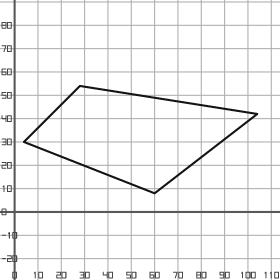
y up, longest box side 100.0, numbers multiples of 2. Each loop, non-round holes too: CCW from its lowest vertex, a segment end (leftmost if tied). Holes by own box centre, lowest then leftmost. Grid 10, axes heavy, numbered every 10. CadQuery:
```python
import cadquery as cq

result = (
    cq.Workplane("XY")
    .moveTo(60.0, 8.0)
    .lineTo(104.0, 42.0)
    .lineTo(28.0, 54.0)
    .lineTo(4.0, 30.0)
    .close()
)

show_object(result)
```